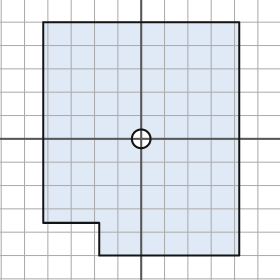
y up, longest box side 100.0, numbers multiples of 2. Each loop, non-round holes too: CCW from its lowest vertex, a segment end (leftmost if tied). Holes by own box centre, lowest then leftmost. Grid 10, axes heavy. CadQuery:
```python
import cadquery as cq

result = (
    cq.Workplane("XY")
    .moveTo(-18.0, -50.0)
    .lineTo(42.0, -50.0)
    .lineTo(42.0, 50.0)
    .lineTo(-42.0, 50.0)
    .lineTo(-42.0, -36.0)
    .lineTo(-18.0, -36.0)
    .close()
    .moveTo(0.0, 0.0)
    .circle(4.0)
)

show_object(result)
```